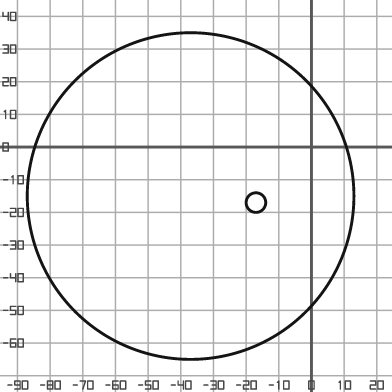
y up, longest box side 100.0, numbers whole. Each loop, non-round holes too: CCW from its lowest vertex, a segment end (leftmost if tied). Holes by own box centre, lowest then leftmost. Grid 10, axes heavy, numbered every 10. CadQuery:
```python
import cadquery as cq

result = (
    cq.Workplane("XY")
    .moveTo(-37.0, -15.0)
    .circle(50.0)
    .moveTo(-17.0, -17.0)
    .circle(3.0)
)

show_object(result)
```